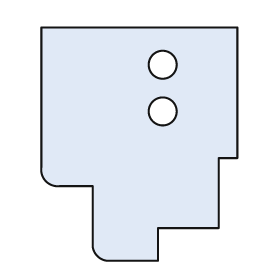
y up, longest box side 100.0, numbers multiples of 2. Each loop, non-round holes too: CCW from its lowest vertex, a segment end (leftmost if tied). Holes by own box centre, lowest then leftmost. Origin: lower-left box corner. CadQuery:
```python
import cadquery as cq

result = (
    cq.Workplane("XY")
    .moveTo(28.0, 0.0)
    .lineTo(50.0, 0.0)
    .lineTo(50.0, 14.0)
    .lineTo(76.0, 14.0)
    .lineTo(76.0, 44.0)
    .lineTo(84.0, 44.0)
    .lineTo(84.0, 100.0)
    .lineTo(0.0, 100.0)
    .lineTo(0.0, 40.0)
    .threePointArc((2.0, 34.0), (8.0, 32.0))
    .lineTo(22.0, 32.0)
    .lineTo(22.0, 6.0)
    .threePointArc((24.0, 2.0), (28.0, 0.0))
    .close()
    .moveTo(52.0, 64.0)
    .circle(6.0)
    .moveTo(52.0, 84.0)
    .circle(6.0)
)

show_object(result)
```